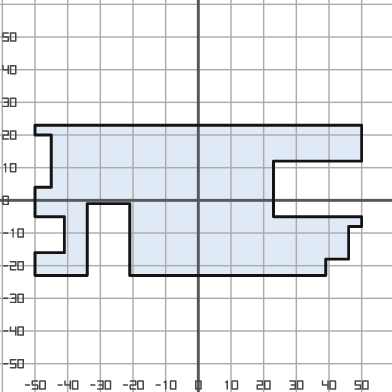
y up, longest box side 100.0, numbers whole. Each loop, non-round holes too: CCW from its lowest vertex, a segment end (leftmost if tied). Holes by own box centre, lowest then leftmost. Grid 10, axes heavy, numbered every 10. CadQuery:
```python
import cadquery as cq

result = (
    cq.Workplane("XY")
    .moveTo(-50.0, -23.0)
    .lineTo(-34.0, -23.0)
    .lineTo(-34.0, -1.0)
    .lineTo(-21.0, -1.0)
    .lineTo(-21.0, -23.0)
    .lineTo(39.0, -23.0)
    .lineTo(39.0, -18.0)
    .lineTo(46.0, -18.0)
    .lineTo(46.0, -8.0)
    .lineTo(50.0, -8.0)
    .lineTo(50.0, -5.0)
    .lineTo(23.0, -5.0)
    .lineTo(23.0, 12.0)
    .lineTo(50.0, 12.0)
    .lineTo(50.0, 23.0)
    .lineTo(-50.0, 23.0)
    .lineTo(-50.0, 20.0)
    .lineTo(-45.0, 20.0)
    .lineTo(-45.0, 4.0)
    .lineTo(-50.0, 4.0)
    .lineTo(-50.0, -5.0)
    .lineTo(-41.0, -5.0)
    .lineTo(-41.0, -16.0)
    .lineTo(-50.0, -16.0)
    .close()
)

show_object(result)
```